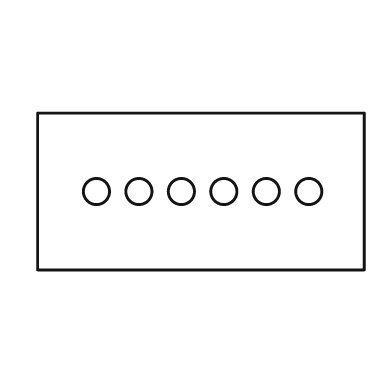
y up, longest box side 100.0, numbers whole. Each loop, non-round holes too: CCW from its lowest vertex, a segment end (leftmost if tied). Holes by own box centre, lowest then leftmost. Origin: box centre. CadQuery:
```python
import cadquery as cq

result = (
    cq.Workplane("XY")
    .moveTo(-50.0, -24.0)
    .lineTo(50.0, -24.0)
    .lineTo(50.0, 24.0)
    .lineTo(-50.0, 24.0)
    .close()
    .moveTo(-32.0, 0.0)
    .circle(4.0)
    .moveTo(-19.0, 0.0)
    .circle(4.0)
    .moveTo(-6.0, 0.0)
    .circle(4.0)
    .moveTo(7.0, 0.0)
    .circle(4.0)
    .moveTo(20.0, 0.0)
    .circle(4.0)
    .moveTo(33.0, 0.0)
    .circle(4.0)
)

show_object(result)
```